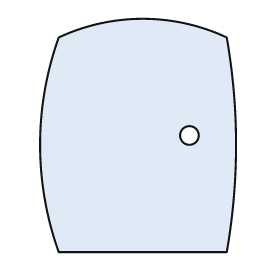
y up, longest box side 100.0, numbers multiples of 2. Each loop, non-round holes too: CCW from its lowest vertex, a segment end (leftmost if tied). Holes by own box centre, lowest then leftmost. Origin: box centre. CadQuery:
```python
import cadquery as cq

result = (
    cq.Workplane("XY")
    .moveTo(-34.0, -50.0)
    .lineTo(38.0, -50.0)
    .threePointArc((42.0, -4.0), (38.0, 42.0))
    .threePointArc((2.0, 50.0), (-34.0, 42.0))
    .threePointArc((-42.0, -4.0), (-34.0, -50.0))
    .close()
    .moveTo(22.0, 0.0)
    .circle(4.0)
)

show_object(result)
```